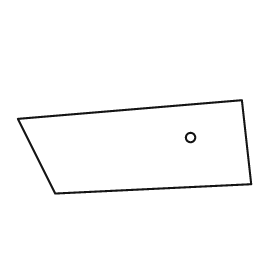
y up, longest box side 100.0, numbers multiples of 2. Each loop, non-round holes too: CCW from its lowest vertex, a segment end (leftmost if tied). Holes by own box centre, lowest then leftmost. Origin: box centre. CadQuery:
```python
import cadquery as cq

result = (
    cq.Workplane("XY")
    .moveTo(-34.0, -20.0)
    .lineTo(50.0, -16.0)
    .lineTo(46.0, 20.0)
    .lineTo(-50.0, 12.0)
    .close()
    .moveTo(24.0, 4.0)
    .circle(2.0)
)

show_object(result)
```